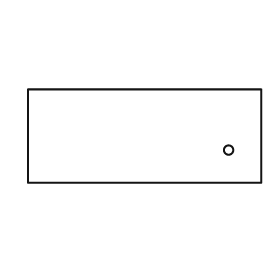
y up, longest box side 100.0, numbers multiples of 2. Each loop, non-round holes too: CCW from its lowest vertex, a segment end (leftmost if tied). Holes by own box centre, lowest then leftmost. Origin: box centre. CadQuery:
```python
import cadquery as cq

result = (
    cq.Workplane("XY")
    .moveTo(-50.0, -20.0)
    .lineTo(50.0, -20.0)
    .lineTo(50.0, 20.0)
    .lineTo(-50.0, 20.0)
    .close()
    .moveTo(36.0, -6.0)
    .circle(2.0)
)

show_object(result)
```